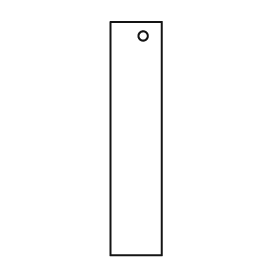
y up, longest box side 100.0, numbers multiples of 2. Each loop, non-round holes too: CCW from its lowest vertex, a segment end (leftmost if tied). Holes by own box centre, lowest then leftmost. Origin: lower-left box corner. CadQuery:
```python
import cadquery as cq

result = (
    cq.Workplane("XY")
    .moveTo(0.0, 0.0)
    .lineTo(22.0, 0.0)
    .lineTo(22.0, 100.0)
    .lineTo(0.0, 100.0)
    .close()
    .moveTo(14.0, 94.0)
    .circle(2.0)
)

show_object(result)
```